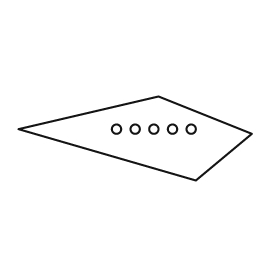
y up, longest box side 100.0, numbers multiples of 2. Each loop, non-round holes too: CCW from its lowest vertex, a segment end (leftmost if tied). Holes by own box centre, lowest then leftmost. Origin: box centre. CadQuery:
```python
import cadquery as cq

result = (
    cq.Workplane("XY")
    .moveTo(26.0, -18.0)
    .lineTo(50.0, 2.0)
    .lineTo(10.0, 18.0)
    .lineTo(-50.0, 4.0)
    .close()
    .moveTo(-8.0, 4.0)
    .circle(2.0)
    .moveTo(0.0, 4.0)
    .circle(2.0)
    .moveTo(8.0, 4.0)
    .circle(2.0)
    .moveTo(16.0, 4.0)
    .circle(2.0)
    .moveTo(24.0, 4.0)
    .circle(2.0)
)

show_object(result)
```